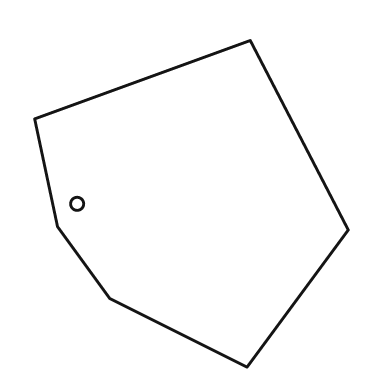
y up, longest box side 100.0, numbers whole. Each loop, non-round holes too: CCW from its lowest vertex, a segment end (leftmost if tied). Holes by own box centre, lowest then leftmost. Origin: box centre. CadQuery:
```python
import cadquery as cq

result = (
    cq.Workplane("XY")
    .moveTo(17.0, -50.0)
    .lineTo(48.0, -8.0)
    .lineTo(18.0, 50.0)
    .lineTo(-48.0, 26.0)
    .lineTo(-41.0, -7.0)
    .lineTo(-25.0, -29.0)
    .close()
    .moveTo(-35.0, 0.0)
    .circle(2.0)
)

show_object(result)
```